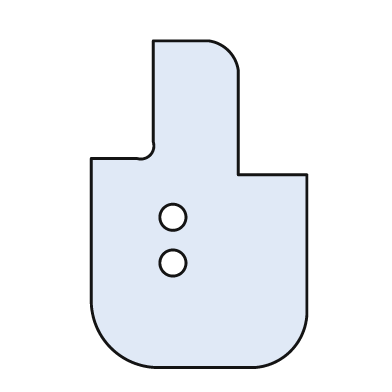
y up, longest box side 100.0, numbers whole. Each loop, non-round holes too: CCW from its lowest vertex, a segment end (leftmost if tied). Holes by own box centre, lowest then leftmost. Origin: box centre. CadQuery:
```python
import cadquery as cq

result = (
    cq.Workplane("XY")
    .moveTo(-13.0, -50.0)
    .lineTo(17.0, -50.0)
    .threePointArc((28.0, -45.0), (33.0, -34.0))
    .lineTo(33.0, 9.0)
    .lineTo(12.0, 9.0)
    .lineTo(12.0, 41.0)
    .threePointArc((9.0, 47.0), (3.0, 50.0))
    .lineTo(-14.0, 50.0)
    .lineTo(-14.0, 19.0)
    .threePointArc((-15.0, 15.0), (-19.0, 14.0))
    .lineTo(-33.0, 14.0)
    .lineTo(-33.0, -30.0)
    .threePointArc((-27.0, -44.0), (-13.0, -50.0))
    .close()
    .moveTo(-8.0, -18.0)
    .circle(4.0)
    .moveTo(-8.0, -4.0)
    .circle(4.0)
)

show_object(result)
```